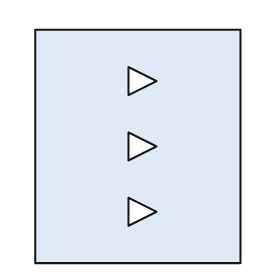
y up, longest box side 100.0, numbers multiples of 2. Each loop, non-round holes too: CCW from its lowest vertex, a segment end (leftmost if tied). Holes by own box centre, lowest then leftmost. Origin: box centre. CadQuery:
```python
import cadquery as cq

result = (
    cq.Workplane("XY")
    .moveTo(-44.0, -50.0)
    .lineTo(44.0, -50.0)
    .lineTo(44.0, 50.0)
    .lineTo(-44.0, 50.0)
    .close()
    .moveTo(-4.0, -34.0)
    .lineTo(8.0, -28.0)
    .lineTo(-4.0, -22.0)
    .close()
    .moveTo(-4.0, -6.0)
    .lineTo(8.0, 0.0)
    .lineTo(-4.0, 6.0)
    .close()
    .moveTo(-4.0, 22.0)
    .lineTo(8.0, 28.0)
    .lineTo(-4.0, 34.0)
    .close()
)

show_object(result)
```